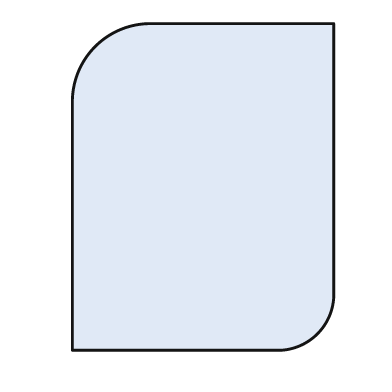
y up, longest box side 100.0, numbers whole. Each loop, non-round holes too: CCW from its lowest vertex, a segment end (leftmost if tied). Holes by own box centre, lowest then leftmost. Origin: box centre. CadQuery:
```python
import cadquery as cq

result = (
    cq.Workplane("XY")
    .moveTo(-40.0, -50.0)
    .lineTo(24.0, -50.0)
    .threePointArc((35.0, -45.0), (40.0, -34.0))
    .lineTo(40.0, 50.0)
    .lineTo(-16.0, 50.0)
    .threePointArc((-33.0, 43.0), (-40.0, 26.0))
    .close()
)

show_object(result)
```